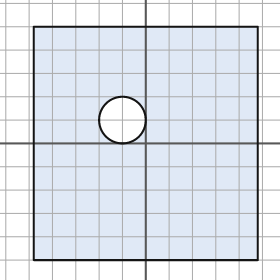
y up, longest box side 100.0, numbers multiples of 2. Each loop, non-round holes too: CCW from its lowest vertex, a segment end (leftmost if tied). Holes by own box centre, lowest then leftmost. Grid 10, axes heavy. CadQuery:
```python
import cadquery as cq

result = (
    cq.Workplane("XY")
    .moveTo(-48.0, -50.0)
    .lineTo(48.0, -50.0)
    .lineTo(48.0, 50.0)
    .lineTo(-48.0, 50.0)
    .close()
    .moveTo(-10.0, 10.0)
    .circle(10.0)
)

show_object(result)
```